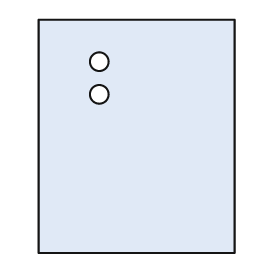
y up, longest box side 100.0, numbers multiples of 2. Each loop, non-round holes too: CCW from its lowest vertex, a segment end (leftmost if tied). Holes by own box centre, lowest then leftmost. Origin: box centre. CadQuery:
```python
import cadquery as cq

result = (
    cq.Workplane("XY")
    .moveTo(-42.0, -50.0)
    .lineTo(42.0, -50.0)
    .lineTo(42.0, 50.0)
    .lineTo(-42.0, 50.0)
    .close()
    .moveTo(-16.0, 18.0)
    .circle(4.0)
    .moveTo(-16.0, 32.0)
    .circle(4.0)
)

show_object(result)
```